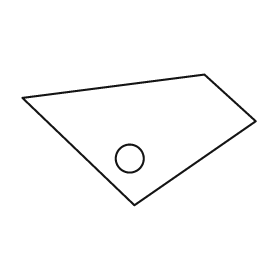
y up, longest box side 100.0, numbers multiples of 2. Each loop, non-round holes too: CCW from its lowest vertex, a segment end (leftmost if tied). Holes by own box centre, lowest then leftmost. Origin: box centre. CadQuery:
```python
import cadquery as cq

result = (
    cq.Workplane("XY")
    .moveTo(-2.0, -28.0)
    .lineTo(50.0, 8.0)
    .lineTo(28.0, 28.0)
    .lineTo(-50.0, 18.0)
    .close()
    .moveTo(-4.0, -8.0)
    .circle(6.0)
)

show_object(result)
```